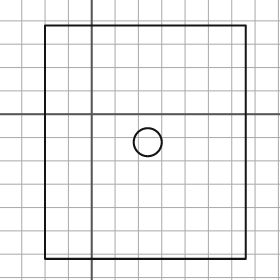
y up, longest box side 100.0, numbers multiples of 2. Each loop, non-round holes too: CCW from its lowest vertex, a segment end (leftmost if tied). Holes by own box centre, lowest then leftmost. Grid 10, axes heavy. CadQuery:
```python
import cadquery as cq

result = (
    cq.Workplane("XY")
    .moveTo(-20.0, -62.0)
    .lineTo(66.0, -62.0)
    .lineTo(66.0, 38.0)
    .lineTo(-20.0, 38.0)
    .close()
    .moveTo(24.0, -12.0)
    .circle(6.0)
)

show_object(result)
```